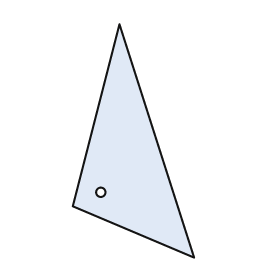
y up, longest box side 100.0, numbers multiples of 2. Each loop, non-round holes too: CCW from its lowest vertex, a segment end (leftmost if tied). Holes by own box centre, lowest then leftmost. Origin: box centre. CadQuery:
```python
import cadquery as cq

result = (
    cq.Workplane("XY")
    .moveTo(26.0, -50.0)
    .lineTo(-6.0, 50.0)
    .lineTo(-26.0, -28.0)
    .close()
    .moveTo(-14.0, -22.0)
    .circle(2.0)
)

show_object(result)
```